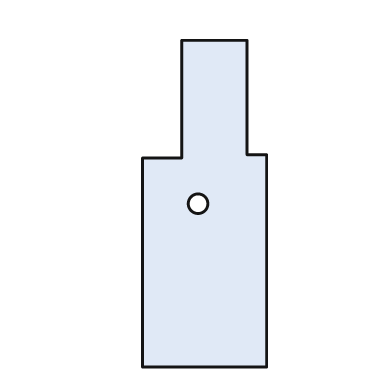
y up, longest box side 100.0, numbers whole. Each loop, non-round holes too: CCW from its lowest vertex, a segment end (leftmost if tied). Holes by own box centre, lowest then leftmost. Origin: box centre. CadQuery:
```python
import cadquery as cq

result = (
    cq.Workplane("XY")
    .moveTo(-19.0, -50.0)
    .lineTo(19.0, -50.0)
    .lineTo(19.0, 15.0)
    .lineTo(13.0, 15.0)
    .lineTo(13.0, 50.0)
    .lineTo(-7.0, 50.0)
    .lineTo(-7.0, 14.0)
    .lineTo(-19.0, 14.0)
    .close()
    .moveTo(-2.0, 0.0)
    .circle(3.0)
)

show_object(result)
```